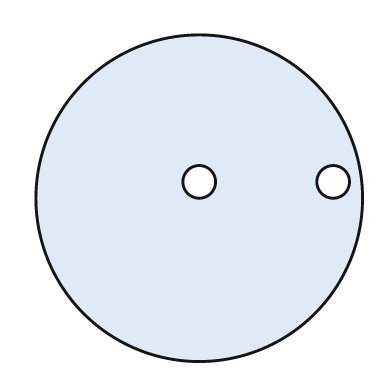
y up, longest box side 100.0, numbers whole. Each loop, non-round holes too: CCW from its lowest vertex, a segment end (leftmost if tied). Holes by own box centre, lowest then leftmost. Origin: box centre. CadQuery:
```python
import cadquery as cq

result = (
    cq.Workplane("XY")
    .moveTo(0.0, 0.0)
    .circle(50.0)
    .moveTo(0.0, 5.0)
    .circle(5.0)
    .moveTo(41.0, 5.0)
    .circle(5.0)
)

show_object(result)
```